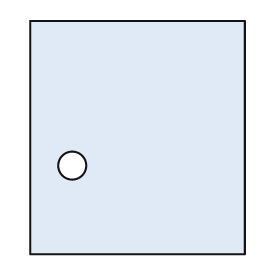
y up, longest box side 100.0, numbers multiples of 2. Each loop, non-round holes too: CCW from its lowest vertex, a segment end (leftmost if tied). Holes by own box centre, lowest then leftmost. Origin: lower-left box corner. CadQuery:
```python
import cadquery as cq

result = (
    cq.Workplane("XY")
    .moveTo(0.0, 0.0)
    .lineTo(92.0, 0.0)
    .lineTo(92.0, 100.0)
    .lineTo(0.0, 100.0)
    .close()
    .moveTo(18.0, 38.0)
    .circle(6.0)
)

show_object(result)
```